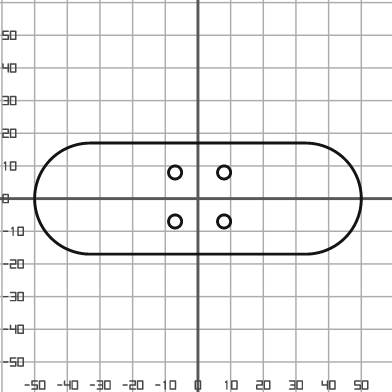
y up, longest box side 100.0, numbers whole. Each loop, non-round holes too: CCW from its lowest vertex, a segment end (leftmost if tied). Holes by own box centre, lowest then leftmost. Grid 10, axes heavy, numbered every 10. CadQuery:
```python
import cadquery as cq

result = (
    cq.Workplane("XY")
    .moveTo(-33.0, -17.0)
    .lineTo(33.0, -17.0)
    .threePointArc((50.0, 0.0), (33.0, 17.0))
    .lineTo(-33.0, 17.0)
    .threePointArc((-50.0, 0.0), (-33.0, -17.0))
    .close()
    .moveTo(-7.0, -7.0)
    .circle(2.0)
    .moveTo(8.0, -7.0)
    .circle(2.0)
    .moveTo(-7.0, 8.0)
    .circle(2.0)
    .moveTo(8.0, 8.0)
    .circle(2.0)
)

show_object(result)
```